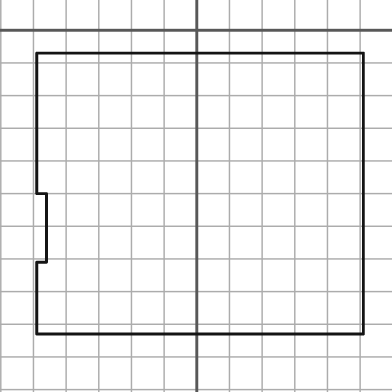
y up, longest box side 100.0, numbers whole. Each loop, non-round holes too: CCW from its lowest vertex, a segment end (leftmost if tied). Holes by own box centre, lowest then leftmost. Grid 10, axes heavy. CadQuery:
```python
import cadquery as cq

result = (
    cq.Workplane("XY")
    .moveTo(-49.0, -93.0)
    .lineTo(51.0, -93.0)
    .lineTo(51.0, -7.0)
    .lineTo(-49.0, -7.0)
    .lineTo(-49.0, -50.0)
    .lineTo(-46.0, -50.0)
    .lineTo(-46.0, -71.0)
    .lineTo(-49.0, -71.0)
    .close()
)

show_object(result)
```